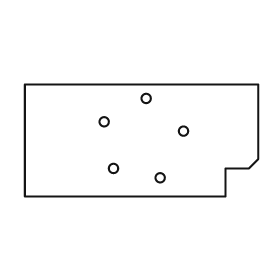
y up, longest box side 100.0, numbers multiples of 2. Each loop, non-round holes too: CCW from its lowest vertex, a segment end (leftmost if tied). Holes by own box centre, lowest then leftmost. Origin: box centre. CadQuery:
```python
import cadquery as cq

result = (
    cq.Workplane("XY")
    .moveTo(-50.0, -24.0)
    .lineTo(36.0, -24.0)
    .lineTo(36.0, -12.0)
    .lineTo(46.0, -12.0)
    .lineTo(50.0, -8.0)
    .lineTo(50.0, 24.0)
    .lineTo(-50.0, 24.0)
    .close()
    .moveTo(8.0, -16.0)
    .circle(2.0)
    .moveTo(-12.0, -12.0)
    .circle(2.0)
    .moveTo(18.0, 4.0)
    .circle(2.0)
    .moveTo(-16.0, 8.0)
    .circle(2.0)
    .moveTo(2.0, 18.0)
    .circle(2.0)
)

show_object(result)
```